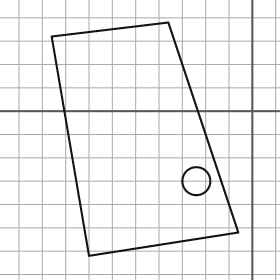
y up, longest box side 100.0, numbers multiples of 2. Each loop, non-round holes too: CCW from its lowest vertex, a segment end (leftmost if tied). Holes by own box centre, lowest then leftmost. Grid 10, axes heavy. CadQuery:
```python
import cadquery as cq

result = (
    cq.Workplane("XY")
    .moveTo(-70.0, -62.0)
    .lineTo(-6.0, -52.0)
    .lineTo(-36.0, 38.0)
    .lineTo(-86.0, 32.0)
    .close()
    .moveTo(-24.0, -30.0)
    .circle(6.0)
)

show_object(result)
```